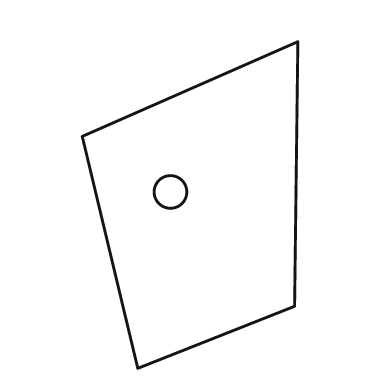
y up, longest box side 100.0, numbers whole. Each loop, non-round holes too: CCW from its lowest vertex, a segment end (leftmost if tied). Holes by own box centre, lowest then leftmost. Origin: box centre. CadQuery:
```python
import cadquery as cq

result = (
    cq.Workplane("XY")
    .moveTo(-16.0, -50.0)
    .lineTo(32.0, -31.0)
    .lineTo(33.0, 50.0)
    .lineTo(-33.0, 21.0)
    .close()
    .moveTo(-6.0, 4.0)
    .circle(5.0)
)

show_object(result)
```